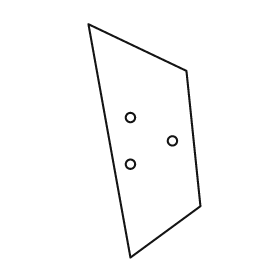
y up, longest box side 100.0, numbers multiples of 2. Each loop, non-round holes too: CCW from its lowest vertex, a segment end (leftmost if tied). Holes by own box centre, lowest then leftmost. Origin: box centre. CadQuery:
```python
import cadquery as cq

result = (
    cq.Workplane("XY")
    .moveTo(-6.0, -50.0)
    .lineTo(24.0, -28.0)
    .lineTo(18.0, 30.0)
    .lineTo(-24.0, 50.0)
    .close()
    .moveTo(-6.0, -10.0)
    .circle(2.0)
    .moveTo(12.0, 0.0)
    .circle(2.0)
    .moveTo(-6.0, 10.0)
    .circle(2.0)
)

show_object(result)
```